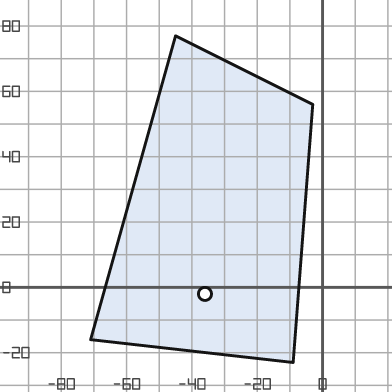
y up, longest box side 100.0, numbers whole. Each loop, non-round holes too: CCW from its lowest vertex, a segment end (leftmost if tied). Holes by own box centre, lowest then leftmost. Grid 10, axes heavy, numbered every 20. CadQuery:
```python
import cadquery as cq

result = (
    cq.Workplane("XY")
    .moveTo(-9.0, -23.0)
    .lineTo(-3.0, 56.0)
    .lineTo(-45.0, 77.0)
    .lineTo(-71.0, -16.0)
    .close()
    .moveTo(-36.0, -2.0)
    .circle(2.0)
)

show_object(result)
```